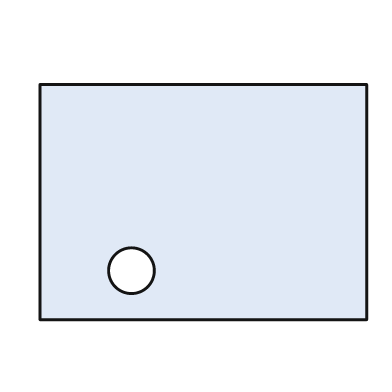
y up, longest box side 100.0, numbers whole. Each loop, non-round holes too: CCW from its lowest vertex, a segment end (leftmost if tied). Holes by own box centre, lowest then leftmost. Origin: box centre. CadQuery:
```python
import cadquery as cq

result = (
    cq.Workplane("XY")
    .moveTo(-50.0, -36.0)
    .lineTo(50.0, -36.0)
    .lineTo(50.0, 36.0)
    .lineTo(-50.0, 36.0)
    .close()
    .moveTo(-22.0, -21.0)
    .circle(7.0)
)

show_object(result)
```